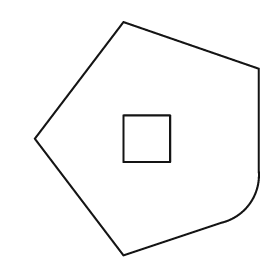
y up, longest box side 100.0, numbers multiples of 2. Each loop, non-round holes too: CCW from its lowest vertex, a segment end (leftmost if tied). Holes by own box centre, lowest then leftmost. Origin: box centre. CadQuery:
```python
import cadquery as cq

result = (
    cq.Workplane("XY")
    .moveTo(-10.0, -50.0)
    .lineTo(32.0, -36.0)
    .threePointArc((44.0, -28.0), (48.0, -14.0))
    .lineTo(48.0, 30.0)
    .lineTo(-10.0, 50.0)
    .lineTo(-48.0, 0.0)
    .close()
    .moveTo(-10.0, -10.0)
    .lineTo(10.0, -10.0)
    .lineTo(10.0, 10.0)
    .lineTo(-10.0, 10.0)
    .close()
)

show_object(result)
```